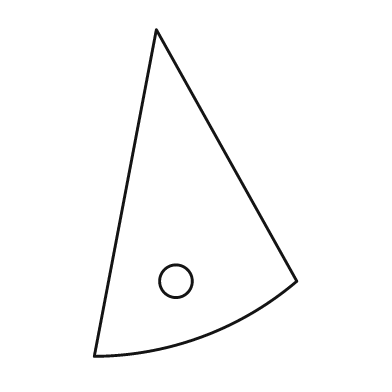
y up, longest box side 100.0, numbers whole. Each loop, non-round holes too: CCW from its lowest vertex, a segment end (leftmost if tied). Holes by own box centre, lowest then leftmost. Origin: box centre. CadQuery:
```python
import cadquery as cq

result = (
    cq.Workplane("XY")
    .moveTo(-31.0, -50.0)
    .threePointArc((2.0, -44.0), (31.0, -27.0))
    .lineTo(-12.0, 50.0)
    .close()
    .moveTo(-6.0, -27.0)
    .circle(5.0)
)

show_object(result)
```